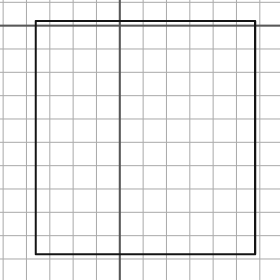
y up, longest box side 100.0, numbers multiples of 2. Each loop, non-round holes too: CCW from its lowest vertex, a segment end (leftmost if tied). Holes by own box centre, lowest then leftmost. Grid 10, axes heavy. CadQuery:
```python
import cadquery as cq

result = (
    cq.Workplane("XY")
    .moveTo(-36.0, -98.0)
    .lineTo(58.0, -98.0)
    .lineTo(58.0, 2.0)
    .lineTo(-36.0, 2.0)
    .close()
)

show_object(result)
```